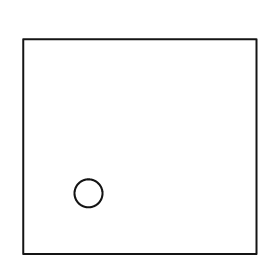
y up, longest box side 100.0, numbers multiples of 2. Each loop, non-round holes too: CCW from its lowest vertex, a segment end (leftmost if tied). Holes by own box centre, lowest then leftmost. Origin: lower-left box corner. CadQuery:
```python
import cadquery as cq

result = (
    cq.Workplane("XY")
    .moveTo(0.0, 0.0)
    .lineTo(100.0, 0.0)
    .lineTo(100.0, 92.0)
    .lineTo(0.0, 92.0)
    .close()
    .moveTo(28.0, 26.0)
    .circle(6.0)
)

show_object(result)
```